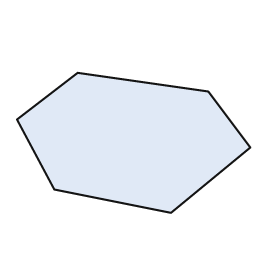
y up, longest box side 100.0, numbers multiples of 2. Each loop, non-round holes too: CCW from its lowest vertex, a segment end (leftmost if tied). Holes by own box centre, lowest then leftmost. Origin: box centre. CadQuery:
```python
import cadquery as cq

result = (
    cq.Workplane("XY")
    .moveTo(16.0, -30.0)
    .lineTo(50.0, -2.0)
    .lineTo(32.0, 22.0)
    .lineTo(-24.0, 30.0)
    .lineTo(-50.0, 10.0)
    .lineTo(-34.0, -20.0)
    .close()
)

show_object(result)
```